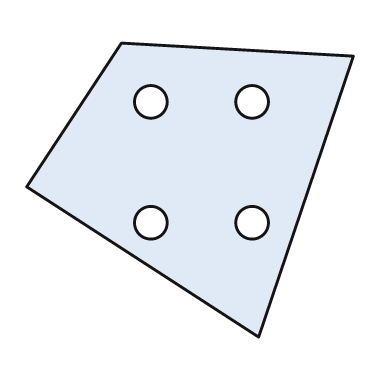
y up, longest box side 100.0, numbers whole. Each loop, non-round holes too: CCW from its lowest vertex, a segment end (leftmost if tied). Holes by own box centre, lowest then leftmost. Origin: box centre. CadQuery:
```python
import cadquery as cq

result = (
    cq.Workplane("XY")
    .moveTo(21.0, -45.0)
    .lineTo(50.0, 41.0)
    .lineTo(-21.0, 45.0)
    .lineTo(-50.0, 1.0)
    .close()
    .moveTo(-12.0, -10.0)
    .circle(5.0)
    .moveTo(19.0, -10.0)
    .circle(5.0)
    .moveTo(-12.0, 27.0)
    .circle(5.0)
    .moveTo(19.0, 27.0)
    .circle(5.0)
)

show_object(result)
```